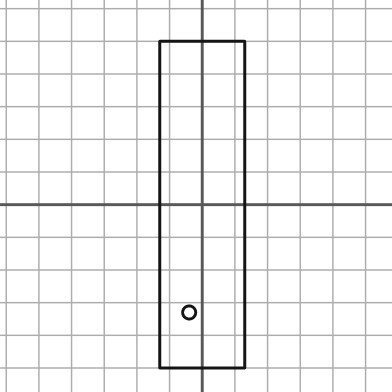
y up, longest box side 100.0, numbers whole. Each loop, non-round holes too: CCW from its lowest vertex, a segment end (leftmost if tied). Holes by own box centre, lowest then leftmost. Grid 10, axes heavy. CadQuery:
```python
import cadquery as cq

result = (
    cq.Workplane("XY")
    .moveTo(-13.0, -50.0)
    .lineTo(13.0, -50.0)
    .lineTo(13.0, 50.0)
    .lineTo(-13.0, 50.0)
    .close()
    .moveTo(-4.0, -33.0)
    .circle(2.0)
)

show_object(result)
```